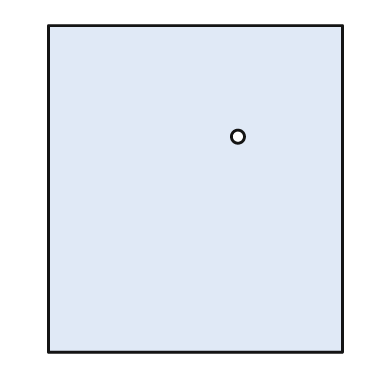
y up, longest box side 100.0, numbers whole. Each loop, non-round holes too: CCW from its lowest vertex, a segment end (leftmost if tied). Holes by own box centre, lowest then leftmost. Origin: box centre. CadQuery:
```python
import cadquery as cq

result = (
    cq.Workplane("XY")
    .moveTo(-45.0, -50.0)
    .lineTo(45.0, -50.0)
    .lineTo(45.0, 50.0)
    .lineTo(-45.0, 50.0)
    .close()
    .moveTo(13.0, 16.0)
    .circle(2.0)
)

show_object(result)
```